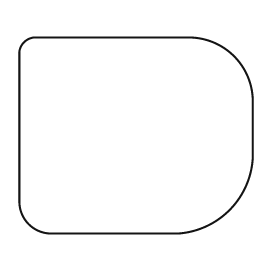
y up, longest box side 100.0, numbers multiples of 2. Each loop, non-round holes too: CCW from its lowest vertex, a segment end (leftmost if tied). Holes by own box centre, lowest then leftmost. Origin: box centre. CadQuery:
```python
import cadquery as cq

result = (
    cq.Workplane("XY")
    .moveTo(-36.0, -42.0)
    .lineTo(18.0, -42.0)
    .threePointArc((40.0, -32.0), (50.0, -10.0))
    .lineTo(50.0, 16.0)
    .threePointArc((42.0, 34.0), (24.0, 42.0))
    .lineTo(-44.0, 42.0)
    .threePointArc((-48.0, 40.0), (-50.0, 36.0))
    .lineTo(-50.0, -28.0)
    .threePointArc((-46.0, -38.0), (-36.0, -42.0))
    .close()
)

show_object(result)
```